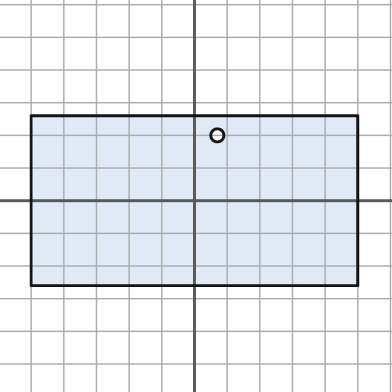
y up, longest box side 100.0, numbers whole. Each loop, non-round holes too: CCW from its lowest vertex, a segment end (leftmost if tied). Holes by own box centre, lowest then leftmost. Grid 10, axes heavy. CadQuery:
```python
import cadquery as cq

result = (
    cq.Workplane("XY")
    .moveTo(-50.0, -26.0)
    .lineTo(50.0, -26.0)
    .lineTo(50.0, 26.0)
    .lineTo(-50.0, 26.0)
    .close()
    .moveTo(7.0, 20.0)
    .circle(2.0)
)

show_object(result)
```